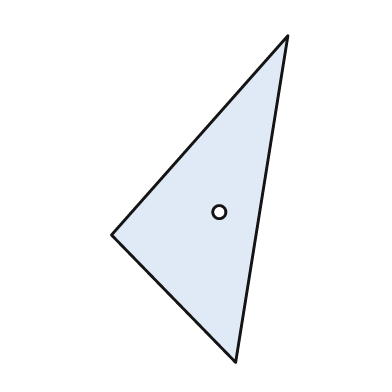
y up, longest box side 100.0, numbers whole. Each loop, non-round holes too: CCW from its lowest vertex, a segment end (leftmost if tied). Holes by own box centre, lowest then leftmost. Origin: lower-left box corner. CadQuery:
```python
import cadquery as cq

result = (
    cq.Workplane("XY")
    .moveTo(38.0, 0.0)
    .lineTo(54.0, 100.0)
    .lineTo(0.0, 39.0)
    .close()
    .moveTo(33.0, 46.0)
    .circle(2.0)
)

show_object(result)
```